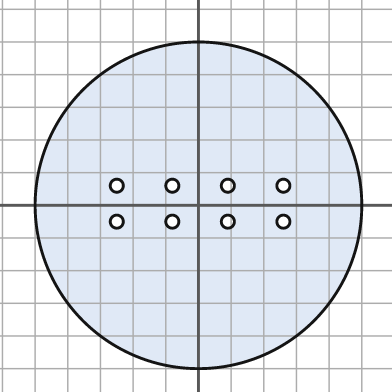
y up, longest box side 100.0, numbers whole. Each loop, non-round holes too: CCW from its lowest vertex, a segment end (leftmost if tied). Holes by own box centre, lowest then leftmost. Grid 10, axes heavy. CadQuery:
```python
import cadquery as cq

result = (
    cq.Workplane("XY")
    .moveTo(0.0, 0.0)
    .circle(50.0)
    .moveTo(-25.0, -5.0)
    .circle(2.0)
    .moveTo(-8.0, -5.0)
    .circle(2.0)
    .moveTo(9.0, -5.0)
    .circle(2.0)
    .moveTo(26.0, -5.0)
    .circle(2.0)
    .moveTo(-25.0, 6.0)
    .circle(2.0)
    .moveTo(-8.0, 6.0)
    .circle(2.0)
    .moveTo(9.0, 6.0)
    .circle(2.0)
    .moveTo(26.0, 6.0)
    .circle(2.0)
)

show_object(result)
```